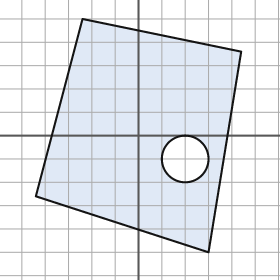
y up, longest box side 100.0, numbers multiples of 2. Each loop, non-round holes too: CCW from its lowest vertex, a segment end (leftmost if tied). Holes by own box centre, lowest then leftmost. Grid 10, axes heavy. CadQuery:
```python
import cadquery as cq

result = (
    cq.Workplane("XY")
    .moveTo(30.0, -50.0)
    .lineTo(44.0, 36.0)
    .lineTo(-24.0, 50.0)
    .lineTo(-44.0, -26.0)
    .close()
    .moveTo(20.0, -10.0)
    .circle(10.0)
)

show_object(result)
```